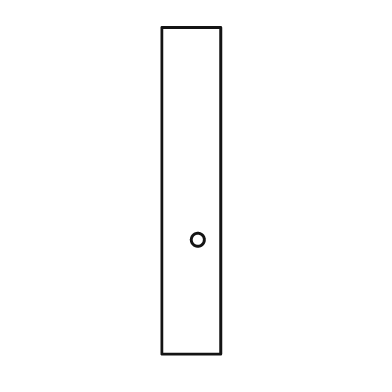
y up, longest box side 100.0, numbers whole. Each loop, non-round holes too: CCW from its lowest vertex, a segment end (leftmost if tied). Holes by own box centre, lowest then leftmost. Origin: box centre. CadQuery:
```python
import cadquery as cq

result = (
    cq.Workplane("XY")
    .moveTo(-9.0, -50.0)
    .lineTo(9.0, -50.0)
    .lineTo(9.0, 50.0)
    .lineTo(-9.0, 50.0)
    .close()
    .moveTo(2.0, -15.0)
    .circle(2.0)
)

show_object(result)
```